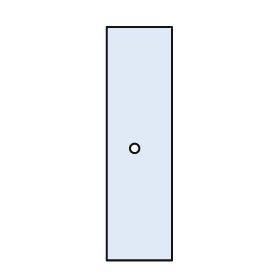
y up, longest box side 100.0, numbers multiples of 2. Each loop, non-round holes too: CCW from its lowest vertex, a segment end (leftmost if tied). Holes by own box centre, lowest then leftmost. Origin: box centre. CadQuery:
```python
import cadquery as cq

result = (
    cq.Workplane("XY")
    .moveTo(-14.0, -50.0)
    .lineTo(14.0, -50.0)
    .lineTo(14.0, 50.0)
    .lineTo(-14.0, 50.0)
    .close()
    .moveTo(-2.0, -2.0)
    .circle(2.0)
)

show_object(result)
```